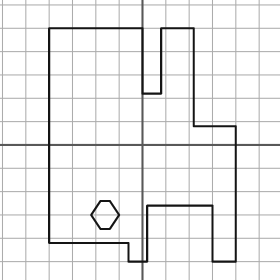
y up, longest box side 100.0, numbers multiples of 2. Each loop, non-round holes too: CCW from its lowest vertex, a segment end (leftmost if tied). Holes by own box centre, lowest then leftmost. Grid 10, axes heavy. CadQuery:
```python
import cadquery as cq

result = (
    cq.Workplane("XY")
    .moveTo(-6.0, -50.0)
    .lineTo(2.0, -50.0)
    .lineTo(2.0, -26.0)
    .lineTo(30.0, -26.0)
    .lineTo(30.0, -50.0)
    .lineTo(40.0, -50.0)
    .lineTo(40.0, 8.0)
    .lineTo(22.0, 8.0)
    .lineTo(22.0, 50.0)
    .lineTo(8.0, 50.0)
    .lineTo(8.0, 22.0)
    .lineTo(0.0, 22.0)
    .lineTo(0.0, 50.0)
    .lineTo(-40.0, 50.0)
    .lineTo(-40.0, -42.0)
    .lineTo(-6.0, -42.0)
    .close()
    .moveTo(-18.0, -36.0)
    .lineTo(-14.0, -36.0)
    .lineTo(-10.0, -30.0)
    .lineTo(-14.0, -24.0)
    .lineTo(-18.0, -24.0)
    .lineTo(-22.0, -30.0)
    .close()
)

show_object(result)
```